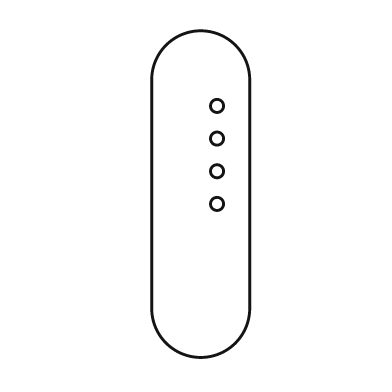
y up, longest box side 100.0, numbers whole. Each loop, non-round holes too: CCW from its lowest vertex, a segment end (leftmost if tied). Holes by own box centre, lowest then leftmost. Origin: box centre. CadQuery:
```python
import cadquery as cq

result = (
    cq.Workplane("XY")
    .moveTo(-15.0, -35.0)
    .threePointArc((0.0, -50.0), (15.0, -35.0))
    .lineTo(15.0, 35.0)
    .threePointArc((0.0, 50.0), (-15.0, 35.0))
    .close()
    .moveTo(5.0, -3.0)
    .circle(2.0)
    .moveTo(5.0, 7.0)
    .circle(2.0)
    .moveTo(5.0, 17.0)
    .circle(2.0)
    .moveTo(5.0, 27.0)
    .circle(2.0)
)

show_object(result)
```